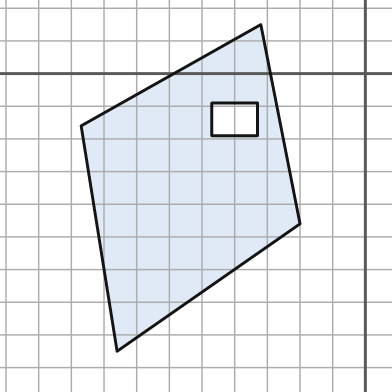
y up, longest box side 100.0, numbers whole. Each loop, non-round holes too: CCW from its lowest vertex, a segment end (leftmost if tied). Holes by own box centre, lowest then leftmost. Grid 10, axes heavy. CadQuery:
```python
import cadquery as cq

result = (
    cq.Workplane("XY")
    .moveTo(-76.0, -85.0)
    .lineTo(-20.0, -46.0)
    .lineTo(-32.0, 15.0)
    .lineTo(-87.0, -16.0)
    .close()
    .moveTo(-47.0, -19.0)
    .lineTo(-33.0, -19.0)
    .lineTo(-33.0, -9.0)
    .lineTo(-47.0, -9.0)
    .close()
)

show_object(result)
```